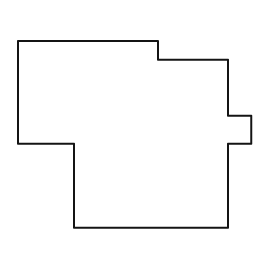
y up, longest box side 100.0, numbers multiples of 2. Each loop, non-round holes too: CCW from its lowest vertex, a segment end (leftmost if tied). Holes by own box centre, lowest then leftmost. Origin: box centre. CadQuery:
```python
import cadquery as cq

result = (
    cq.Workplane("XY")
    .moveTo(-26.0, -40.0)
    .lineTo(40.0, -40.0)
    .lineTo(40.0, -4.0)
    .lineTo(50.0, -4.0)
    .lineTo(50.0, 8.0)
    .lineTo(40.0, 8.0)
    .lineTo(40.0, 32.0)
    .lineTo(10.0, 32.0)
    .lineTo(10.0, 40.0)
    .lineTo(-50.0, 40.0)
    .lineTo(-50.0, -4.0)
    .lineTo(-26.0, -4.0)
    .close()
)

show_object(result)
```